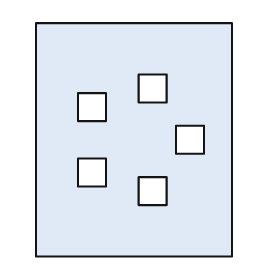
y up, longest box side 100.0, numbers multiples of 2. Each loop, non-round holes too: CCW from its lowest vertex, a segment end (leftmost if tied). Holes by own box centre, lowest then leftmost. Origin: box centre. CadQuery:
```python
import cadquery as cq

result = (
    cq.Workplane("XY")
    .moveTo(-42.0, -50.0)
    .lineTo(42.0, -50.0)
    .lineTo(42.0, 50.0)
    .lineTo(-42.0, 50.0)
    .close()
    .moveTo(2.0, -28.0)
    .lineTo(14.0, -28.0)
    .lineTo(14.0, -16.0)
    .lineTo(2.0, -16.0)
    .close()
    .moveTo(-24.0, -20.0)
    .lineTo(-12.0, -20.0)
    .lineTo(-12.0, -8.0)
    .lineTo(-24.0, -8.0)
    .close()
    .moveTo(18.0, -6.0)
    .lineTo(30.0, -6.0)
    .lineTo(30.0, 6.0)
    .lineTo(18.0, 6.0)
    .close()
    .moveTo(-24.0, 8.0)
    .lineTo(-12.0, 8.0)
    .lineTo(-12.0, 20.0)
    .lineTo(-24.0, 20.0)
    .close()
    .moveTo(2.0, 16.0)
    .lineTo(14.0, 16.0)
    .lineTo(14.0, 28.0)
    .lineTo(2.0, 28.0)
    .close()
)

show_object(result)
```